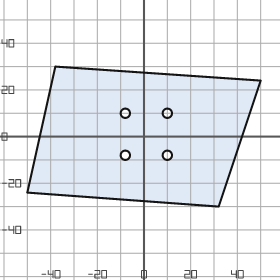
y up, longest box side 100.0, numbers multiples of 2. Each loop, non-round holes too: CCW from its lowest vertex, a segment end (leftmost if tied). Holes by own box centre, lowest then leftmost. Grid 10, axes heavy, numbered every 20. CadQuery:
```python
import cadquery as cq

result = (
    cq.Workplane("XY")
    .moveTo(32.0, -30.0)
    .lineTo(50.0, 24.0)
    .lineTo(-38.0, 30.0)
    .lineTo(-50.0, -24.0)
    .close()
    .moveTo(-8.0, -8.0)
    .circle(2.0)
    .moveTo(10.0, -8.0)
    .circle(2.0)
    .moveTo(-8.0, 10.0)
    .circle(2.0)
    .moveTo(10.0, 10.0)
    .circle(2.0)
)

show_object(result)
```